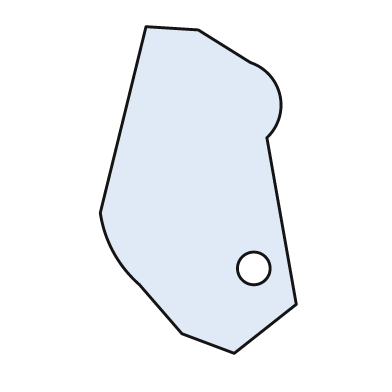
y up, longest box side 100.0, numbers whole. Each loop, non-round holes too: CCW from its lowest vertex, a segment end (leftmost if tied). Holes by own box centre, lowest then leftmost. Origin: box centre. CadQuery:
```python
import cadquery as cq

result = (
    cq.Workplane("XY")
    .moveTo(11.0, -50.0)
    .lineTo(30.0, -35.0)
    .lineTo(21.0, 16.0)
    .threePointArc((25.0, 29.0), (16.0, 39.0))
    .lineTo(0.0, 49.0)
    .lineTo(-16.0, 50.0)
    .lineTo(-30.0, -7.0)
    .threePointArc((-26.0, -19.0), (-18.0, -29.0))
    .lineTo(-5.0, -44.0)
    .close()
    .moveTo(17.0, -24.0)
    .circle(5.0)
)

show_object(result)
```